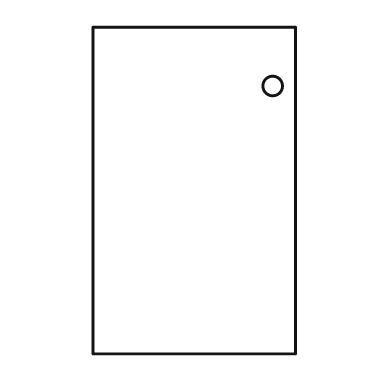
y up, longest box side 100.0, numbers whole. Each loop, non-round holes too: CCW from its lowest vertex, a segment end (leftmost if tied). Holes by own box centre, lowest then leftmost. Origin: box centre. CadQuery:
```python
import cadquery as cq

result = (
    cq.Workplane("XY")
    .moveTo(-31.0, -50.0)
    .lineTo(31.0, -50.0)
    .lineTo(31.0, 50.0)
    .lineTo(-31.0, 50.0)
    .close()
    .moveTo(24.0, 32.0)
    .circle(3.0)
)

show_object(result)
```